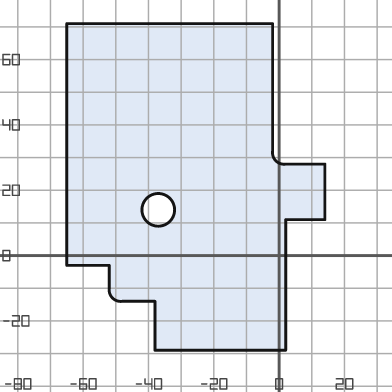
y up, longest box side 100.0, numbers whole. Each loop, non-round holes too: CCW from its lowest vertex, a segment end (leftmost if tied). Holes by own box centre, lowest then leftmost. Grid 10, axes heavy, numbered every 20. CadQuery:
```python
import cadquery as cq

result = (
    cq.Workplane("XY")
    .moveTo(-38.0, -29.0)
    .lineTo(2.0, -29.0)
    .lineTo(2.0, 11.0)
    .lineTo(14.0, 11.0)
    .lineTo(14.0, 28.0)
    .lineTo(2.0, 28.0)
    .threePointArc((-1.0, 29.0), (-2.0, 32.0))
    .lineTo(-2.0, 71.0)
    .lineTo(-65.0, 71.0)
    .lineTo(-65.0, -3.0)
    .lineTo(-52.0, -3.0)
    .lineTo(-52.0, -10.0)
    .threePointArc((-51.0, -13.0), (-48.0, -14.0))
    .lineTo(-38.0, -14.0)
    .close()
    .moveTo(-37.0, 14.0)
    .circle(5.0)
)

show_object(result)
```